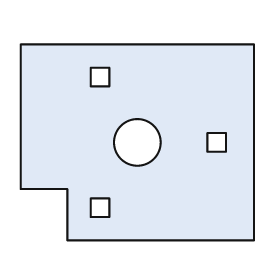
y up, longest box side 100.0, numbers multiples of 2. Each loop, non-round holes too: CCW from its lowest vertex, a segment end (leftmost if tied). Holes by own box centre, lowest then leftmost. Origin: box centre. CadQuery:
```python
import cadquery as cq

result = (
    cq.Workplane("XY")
    .moveTo(-30.0, -42.0)
    .lineTo(50.0, -42.0)
    .lineTo(50.0, 42.0)
    .lineTo(-50.0, 42.0)
    .lineTo(-50.0, -20.0)
    .lineTo(-30.0, -20.0)
    .close()
    .moveTo(-20.0, -32.0)
    .lineTo(-12.0, -32.0)
    .lineTo(-12.0, -24.0)
    .lineTo(-20.0, -24.0)
    .close()
    .moveTo(0.0, 0.0)
    .circle(10.0)
    .moveTo(30.0, -4.0)
    .lineTo(38.0, -4.0)
    .lineTo(38.0, 4.0)
    .lineTo(30.0, 4.0)
    .close()
    .moveTo(-20.0, 24.0)
    .lineTo(-12.0, 24.0)
    .lineTo(-12.0, 32.0)
    .lineTo(-20.0, 32.0)
    .close()
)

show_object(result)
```